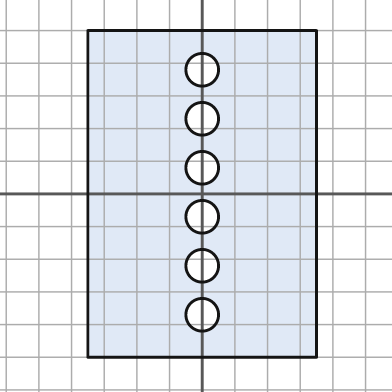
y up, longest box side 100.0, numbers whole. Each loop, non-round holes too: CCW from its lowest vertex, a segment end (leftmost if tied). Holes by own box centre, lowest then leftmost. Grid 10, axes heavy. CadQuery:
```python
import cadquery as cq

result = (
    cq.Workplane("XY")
    .moveTo(-35.0, -50.0)
    .lineTo(35.0, -50.0)
    .lineTo(35.0, 50.0)
    .lineTo(-35.0, 50.0)
    .close()
    .moveTo(0.0, -37.0)
    .circle(5.0)
    .moveTo(0.0, -22.0)
    .circle(5.0)
    .moveTo(0.0, -7.0)
    .circle(5.0)
    .moveTo(0.0, 8.0)
    .circle(5.0)
    .moveTo(0.0, 23.0)
    .circle(5.0)
    .moveTo(0.0, 38.0)
    .circle(5.0)
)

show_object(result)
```